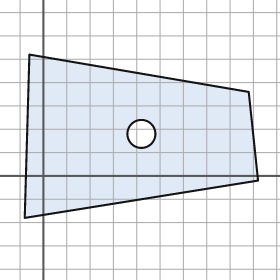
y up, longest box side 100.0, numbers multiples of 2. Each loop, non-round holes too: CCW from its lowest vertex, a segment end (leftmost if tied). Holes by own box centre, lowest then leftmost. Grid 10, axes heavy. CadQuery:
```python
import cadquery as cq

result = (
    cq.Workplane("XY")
    .moveTo(-8.0, -18.0)
    .lineTo(92.0, -2.0)
    .lineTo(88.0, 36.0)
    .lineTo(-6.0, 52.0)
    .close()
    .moveTo(42.0, 18.0)
    .circle(6.0)
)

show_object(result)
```